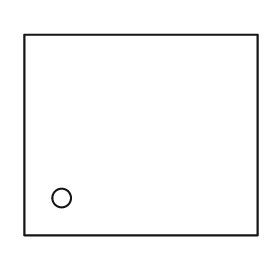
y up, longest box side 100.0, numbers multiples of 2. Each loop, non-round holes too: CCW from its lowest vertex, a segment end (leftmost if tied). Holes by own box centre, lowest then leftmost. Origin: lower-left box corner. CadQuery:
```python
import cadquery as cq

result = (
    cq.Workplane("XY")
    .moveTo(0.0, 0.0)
    .lineTo(100.0, 0.0)
    .lineTo(100.0, 86.0)
    .lineTo(0.0, 86.0)
    .close()
    .moveTo(16.0, 16.0)
    .circle(4.0)
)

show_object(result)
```